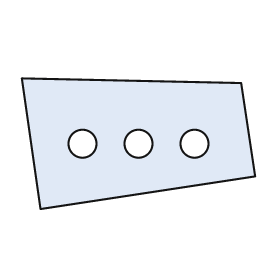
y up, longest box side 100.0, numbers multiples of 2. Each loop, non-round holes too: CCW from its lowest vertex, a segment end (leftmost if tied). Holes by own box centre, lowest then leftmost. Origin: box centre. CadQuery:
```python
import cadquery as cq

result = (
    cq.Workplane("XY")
    .moveTo(-42.0, -28.0)
    .lineTo(50.0, -14.0)
    .lineTo(44.0, 26.0)
    .lineTo(-50.0, 28.0)
    .close()
    .moveTo(-24.0, 0.0)
    .circle(6.0)
    .moveTo(0.0, 0.0)
    .circle(6.0)
    .moveTo(24.0, 0.0)
    .circle(6.0)
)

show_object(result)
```